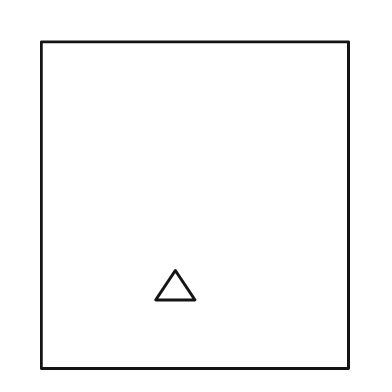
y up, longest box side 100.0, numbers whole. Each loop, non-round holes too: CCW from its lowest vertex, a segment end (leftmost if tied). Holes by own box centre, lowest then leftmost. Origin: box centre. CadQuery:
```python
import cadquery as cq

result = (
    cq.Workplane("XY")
    .moveTo(-47.0, -50.0)
    .lineTo(47.0, -50.0)
    .lineTo(47.0, 50.0)
    .lineTo(-47.0, 50.0)
    .close()
    .moveTo(-12.0, -29.0)
    .lineTo(0.0, -29.0)
    .lineTo(-6.0, -20.0)
    .close()
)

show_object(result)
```